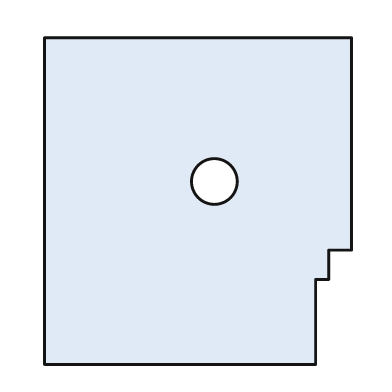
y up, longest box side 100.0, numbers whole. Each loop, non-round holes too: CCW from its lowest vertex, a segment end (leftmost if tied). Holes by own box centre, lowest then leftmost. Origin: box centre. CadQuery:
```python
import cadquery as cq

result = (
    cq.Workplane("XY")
    .moveTo(-47.0, -50.0)
    .lineTo(36.0, -50.0)
    .lineTo(36.0, -24.0)
    .lineTo(40.0, -24.0)
    .lineTo(40.0, -15.0)
    .lineTo(47.0, -15.0)
    .lineTo(47.0, 50.0)
    .lineTo(-47.0, 50.0)
    .close()
    .moveTo(5.0, 6.0)
    .circle(7.0)
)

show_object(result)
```